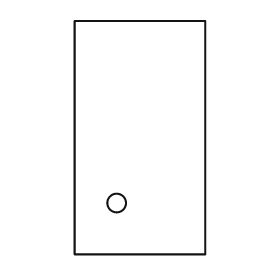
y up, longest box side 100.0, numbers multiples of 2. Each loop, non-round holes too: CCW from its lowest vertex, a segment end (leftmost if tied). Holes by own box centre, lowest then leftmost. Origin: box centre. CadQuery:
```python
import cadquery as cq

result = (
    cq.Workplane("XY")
    .moveTo(-28.0, -50.0)
    .lineTo(28.0, -50.0)
    .lineTo(28.0, 50.0)
    .lineTo(-28.0, 50.0)
    .close()
    .moveTo(-10.0, -28.0)
    .circle(4.0)
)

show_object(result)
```